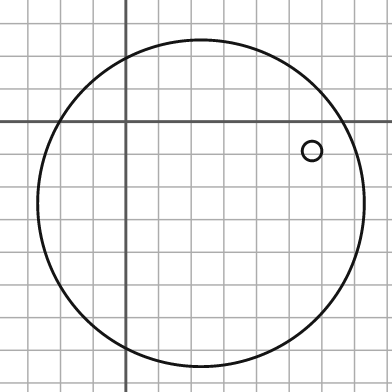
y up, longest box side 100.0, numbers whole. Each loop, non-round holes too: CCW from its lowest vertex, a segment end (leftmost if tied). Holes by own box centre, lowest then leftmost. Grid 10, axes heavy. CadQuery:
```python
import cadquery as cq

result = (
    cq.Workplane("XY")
    .moveTo(23.0, -25.0)
    .circle(50.0)
    .moveTo(57.0, -9.0)
    .circle(3.0)
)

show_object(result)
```